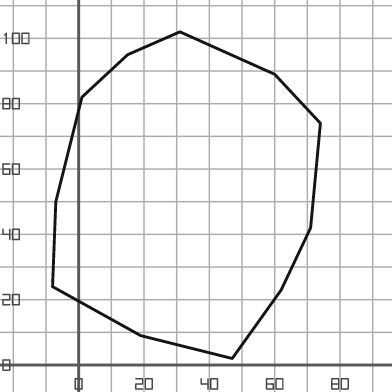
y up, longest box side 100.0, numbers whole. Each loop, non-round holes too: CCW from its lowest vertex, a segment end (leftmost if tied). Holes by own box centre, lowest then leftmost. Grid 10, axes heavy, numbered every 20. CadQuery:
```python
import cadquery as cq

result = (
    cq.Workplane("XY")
    .moveTo(47.0, 2.0)
    .lineTo(62.0, 23.0)
    .lineTo(71.0, 42.0)
    .lineTo(74.0, 74.0)
    .lineTo(60.0, 89.0)
    .lineTo(31.0, 102.0)
    .lineTo(15.0, 95.0)
    .lineTo(1.0, 82.0)
    .lineTo(-7.0, 50.0)
    .lineTo(-8.0, 24.0)
    .lineTo(19.0, 9.0)
    .close()
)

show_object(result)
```